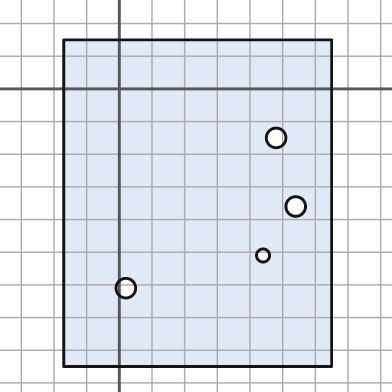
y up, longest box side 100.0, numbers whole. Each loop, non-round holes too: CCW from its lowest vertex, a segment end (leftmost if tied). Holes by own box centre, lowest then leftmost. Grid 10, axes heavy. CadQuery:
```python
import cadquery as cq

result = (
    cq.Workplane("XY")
    .moveTo(-17.0, -85.0)
    .lineTo(65.0, -85.0)
    .lineTo(65.0, 15.0)
    .lineTo(-17.0, 15.0)
    .close()
    .moveTo(2.0, -61.0)
    .circle(3.0)
    .moveTo(44.0, -51.0)
    .circle(2.0)
    .moveTo(54.0, -36.0)
    .circle(3.0)
    .moveTo(48.0, -15.0)
    .circle(3.0)
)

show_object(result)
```